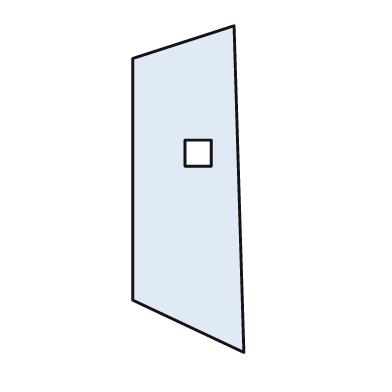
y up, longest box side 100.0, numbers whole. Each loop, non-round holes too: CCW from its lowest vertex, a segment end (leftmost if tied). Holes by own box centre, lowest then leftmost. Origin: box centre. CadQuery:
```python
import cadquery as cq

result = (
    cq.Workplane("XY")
    .moveTo(17.0, -50.0)
    .lineTo(14.0, 50.0)
    .lineTo(-17.0, 40.0)
    .lineTo(-17.0, -34.0)
    .close()
    .moveTo(-1.0, 7.0)
    .lineTo(7.0, 7.0)
    .lineTo(7.0, 15.0)
    .lineTo(-1.0, 15.0)
    .close()
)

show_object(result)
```